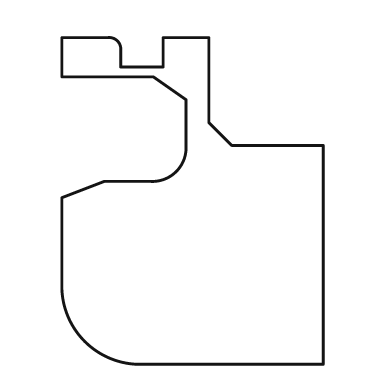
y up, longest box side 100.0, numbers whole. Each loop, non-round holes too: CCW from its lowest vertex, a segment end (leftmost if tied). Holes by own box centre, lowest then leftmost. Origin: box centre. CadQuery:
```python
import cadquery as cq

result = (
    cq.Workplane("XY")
    .moveTo(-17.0, -50.0)
    .lineTo(40.0, -50.0)
    .lineTo(40.0, 17.0)
    .lineTo(12.0, 17.0)
    .lineTo(5.0, 24.0)
    .lineTo(5.0, 50.0)
    .lineTo(-9.0, 50.0)
    .lineTo(-9.0, 41.0)
    .lineTo(-22.0, 41.0)
    .lineTo(-22.0, 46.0)
    .threePointArc((-23.0, 49.0), (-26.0, 50.0))
    .lineTo(-40.0, 50.0)
    .lineTo(-40.0, 38.0)
    .lineTo(-12.0, 38.0)
    .lineTo(-2.0, 31.0)
    .lineTo(-2.0, 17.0)
    .threePointArc((-5.0, 9.0), (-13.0, 6.0))
    .lineTo(-27.0, 6.0)
    .lineTo(-40.0, 1.0)
    .lineTo(-40.0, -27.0)
    .threePointArc((-33.0, -43.0), (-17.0, -50.0))
    .close()
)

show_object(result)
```